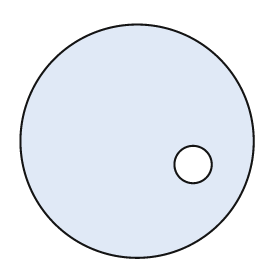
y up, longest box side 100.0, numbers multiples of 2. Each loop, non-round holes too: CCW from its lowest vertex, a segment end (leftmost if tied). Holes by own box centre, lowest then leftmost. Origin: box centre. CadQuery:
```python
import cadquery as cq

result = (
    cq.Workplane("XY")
    .moveTo(0.0, 0.0)
    .circle(50.0)
    .moveTo(24.0, -10.0)
    .circle(8.0)
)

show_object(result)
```